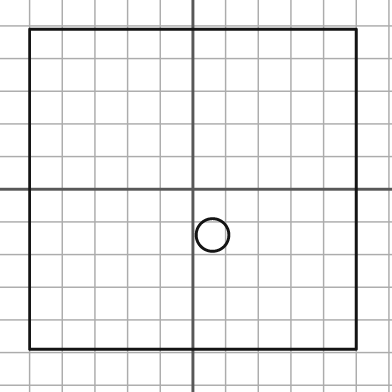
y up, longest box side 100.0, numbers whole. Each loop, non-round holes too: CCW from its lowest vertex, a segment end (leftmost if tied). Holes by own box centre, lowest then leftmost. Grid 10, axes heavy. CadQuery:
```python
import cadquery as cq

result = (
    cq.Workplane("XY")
    .moveTo(-50.0, -49.0)
    .lineTo(50.0, -49.0)
    .lineTo(50.0, 49.0)
    .lineTo(-50.0, 49.0)
    .close()
    .moveTo(6.0, -14.0)
    .circle(5.0)
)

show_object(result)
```